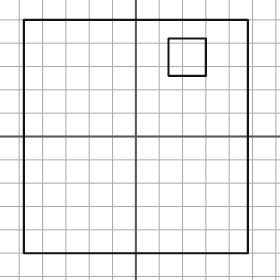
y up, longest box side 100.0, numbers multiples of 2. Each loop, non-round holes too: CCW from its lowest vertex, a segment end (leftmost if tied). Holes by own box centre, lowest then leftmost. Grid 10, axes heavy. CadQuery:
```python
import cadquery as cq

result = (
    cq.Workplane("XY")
    .moveTo(-48.0, -50.0)
    .lineTo(48.0, -50.0)
    .lineTo(48.0, 50.0)
    .lineTo(-48.0, 50.0)
    .close()
    .moveTo(14.0, 26.0)
    .lineTo(30.0, 26.0)
    .lineTo(30.0, 42.0)
    .lineTo(14.0, 42.0)
    .close()
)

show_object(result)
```